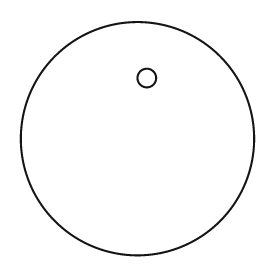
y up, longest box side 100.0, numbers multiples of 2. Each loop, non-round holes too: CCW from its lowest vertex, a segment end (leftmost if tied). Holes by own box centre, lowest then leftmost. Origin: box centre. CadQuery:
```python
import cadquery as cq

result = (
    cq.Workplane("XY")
    .moveTo(0.0, 0.0)
    .circle(50.0)
    .moveTo(4.0, 26.0)
    .circle(4.0)
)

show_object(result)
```